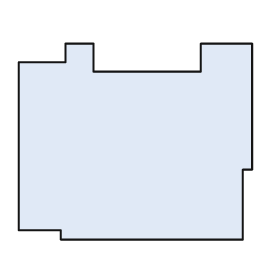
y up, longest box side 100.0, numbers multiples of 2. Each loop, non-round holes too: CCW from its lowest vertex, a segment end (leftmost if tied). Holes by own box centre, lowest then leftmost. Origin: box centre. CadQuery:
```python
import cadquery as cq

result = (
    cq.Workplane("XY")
    .moveTo(-32.0, -42.0)
    .lineTo(46.0, -42.0)
    .lineTo(46.0, -12.0)
    .lineTo(50.0, -12.0)
    .lineTo(50.0, 42.0)
    .lineTo(28.0, 42.0)
    .lineTo(28.0, 30.0)
    .lineTo(-18.0, 30.0)
    .lineTo(-18.0, 42.0)
    .lineTo(-30.0, 42.0)
    .lineTo(-30.0, 34.0)
    .lineTo(-50.0, 34.0)
    .lineTo(-50.0, -38.0)
    .lineTo(-32.0, -38.0)
    .close()
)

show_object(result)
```